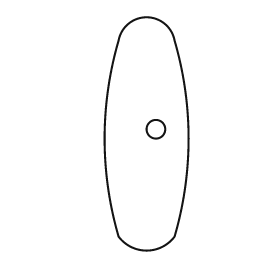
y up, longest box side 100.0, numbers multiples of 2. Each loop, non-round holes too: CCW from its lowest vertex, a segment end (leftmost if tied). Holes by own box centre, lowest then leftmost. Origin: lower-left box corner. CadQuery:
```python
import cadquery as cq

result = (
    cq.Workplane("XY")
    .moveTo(6.0, 6.0)
    .threePointArc((18.0, 0.0), (30.0, 6.0))
    .threePointArc((36.0, 48.0), (30.0, 90.0))
    .threePointArc((18.0, 100.0), (6.0, 90.0))
    .threePointArc((0.0, 48.0), (6.0, 6.0))
    .close()
    .moveTo(22.0, 52.0)
    .circle(4.0)
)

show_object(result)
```